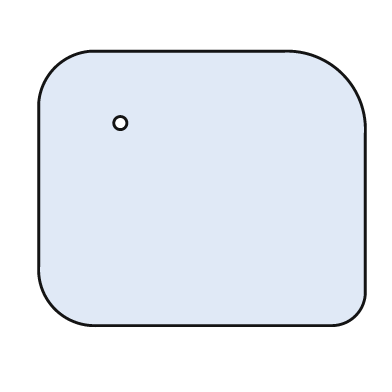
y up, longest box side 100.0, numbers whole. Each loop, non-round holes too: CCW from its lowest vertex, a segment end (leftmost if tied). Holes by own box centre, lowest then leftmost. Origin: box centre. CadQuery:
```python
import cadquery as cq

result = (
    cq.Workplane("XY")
    .moveTo(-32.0, -42.0)
    .lineTo(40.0, -42.0)
    .threePointArc((47.0, -39.0), (50.0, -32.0))
    .lineTo(50.0, 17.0)
    .threePointArc((43.0, 35.0), (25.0, 42.0))
    .lineTo(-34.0, 42.0)
    .threePointArc((-45.0, 37.0), (-50.0, 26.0))
    .lineTo(-50.0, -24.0)
    .threePointArc((-45.0, -37.0), (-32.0, -42.0))
    .close()
    .moveTo(-25.0, 20.0)
    .circle(2.0)
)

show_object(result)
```